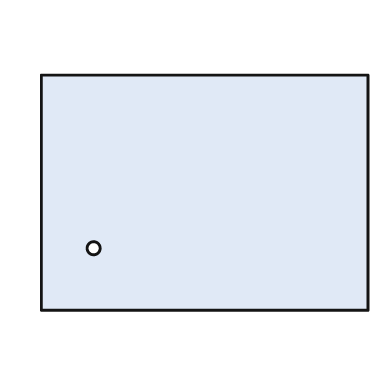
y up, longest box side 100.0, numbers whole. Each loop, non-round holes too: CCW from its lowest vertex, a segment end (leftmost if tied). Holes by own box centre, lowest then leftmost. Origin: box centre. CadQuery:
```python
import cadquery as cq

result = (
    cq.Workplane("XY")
    .moveTo(-50.0, -36.0)
    .lineTo(50.0, -36.0)
    .lineTo(50.0, 36.0)
    .lineTo(-50.0, 36.0)
    .close()
    .moveTo(-34.0, -17.0)
    .circle(2.0)
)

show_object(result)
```